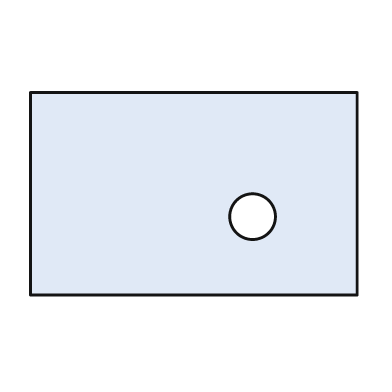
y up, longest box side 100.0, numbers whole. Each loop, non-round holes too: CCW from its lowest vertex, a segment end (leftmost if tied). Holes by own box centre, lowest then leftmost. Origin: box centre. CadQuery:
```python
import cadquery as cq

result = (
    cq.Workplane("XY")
    .moveTo(-50.0, -31.0)
    .lineTo(50.0, -31.0)
    .lineTo(50.0, 31.0)
    .lineTo(-50.0, 31.0)
    .close()
    .moveTo(18.0, -7.0)
    .circle(7.0)
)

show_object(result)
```